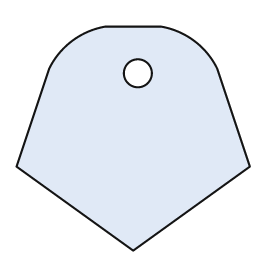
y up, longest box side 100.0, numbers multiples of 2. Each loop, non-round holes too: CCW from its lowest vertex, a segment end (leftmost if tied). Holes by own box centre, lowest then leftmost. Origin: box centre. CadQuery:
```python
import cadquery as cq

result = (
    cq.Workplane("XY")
    .moveTo(0.0, -48.0)
    .lineTo(50.0, -12.0)
    .lineTo(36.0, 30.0)
    .threePointArc((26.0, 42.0), (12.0, 48.0))
    .lineTo(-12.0, 48.0)
    .threePointArc((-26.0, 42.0), (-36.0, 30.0))
    .lineTo(-50.0, -12.0)
    .close()
    .moveTo(2.0, 28.0)
    .circle(6.0)
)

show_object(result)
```